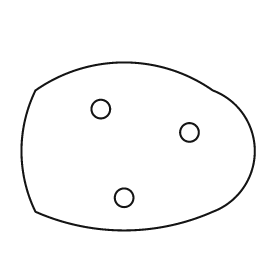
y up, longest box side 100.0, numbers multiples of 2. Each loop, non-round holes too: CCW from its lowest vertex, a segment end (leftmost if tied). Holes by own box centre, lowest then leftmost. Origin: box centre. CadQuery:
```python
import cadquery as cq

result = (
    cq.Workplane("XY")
    .moveTo(-44.0, -28.0)
    .threePointArc((-6.0, -36.0), (32.0, -28.0))
    .threePointArc((50.0, -2.0), (32.0, 24.0))
    .threePointArc((-6.0, 36.0), (-44.0, 24.0))
    .threePointArc((-50.0, -2.0), (-44.0, -28.0))
    .close()
    .moveTo(-6.0, -22.0)
    .circle(4.0)
    .moveTo(22.0, 6.0)
    .circle(4.0)
    .moveTo(-16.0, 16.0)
    .circle(4.0)
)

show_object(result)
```